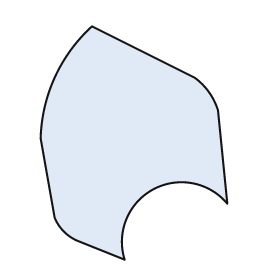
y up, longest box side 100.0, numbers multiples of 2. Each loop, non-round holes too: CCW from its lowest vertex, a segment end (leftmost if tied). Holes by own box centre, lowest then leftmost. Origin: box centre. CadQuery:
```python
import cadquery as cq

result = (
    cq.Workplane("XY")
    .moveTo(-4.0, -50.0)
    .threePointArc((8.0, -20.0), (40.0, -26.0))
    .lineTo(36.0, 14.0)
    .threePointArc((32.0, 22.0), (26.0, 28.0))
    .lineTo(-18.0, 50.0)
    .threePointArc((-34.0, 28.0), (-40.0, 2.0))
    .lineTo(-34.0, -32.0)
    .threePointArc((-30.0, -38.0), (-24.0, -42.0))
    .close()
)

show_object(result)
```